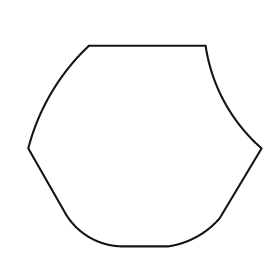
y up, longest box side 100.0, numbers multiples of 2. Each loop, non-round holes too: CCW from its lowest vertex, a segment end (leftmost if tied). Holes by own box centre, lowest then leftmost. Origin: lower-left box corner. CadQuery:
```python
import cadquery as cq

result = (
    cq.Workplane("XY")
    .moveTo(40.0, 0.0)
    .lineTo(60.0, 0.0)
    .threePointArc((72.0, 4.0), (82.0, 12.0))
    .lineTo(100.0, 42.0)
    .threePointArc((84.0, 62.0), (76.0, 86.0))
    .lineTo(26.0, 86.0)
    .threePointArc((10.0, 66.0), (0.0, 42.0))
    .lineTo(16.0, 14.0)
    .threePointArc((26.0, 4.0), (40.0, 0.0))
    .close()
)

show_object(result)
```